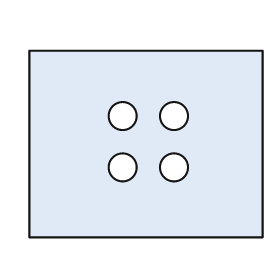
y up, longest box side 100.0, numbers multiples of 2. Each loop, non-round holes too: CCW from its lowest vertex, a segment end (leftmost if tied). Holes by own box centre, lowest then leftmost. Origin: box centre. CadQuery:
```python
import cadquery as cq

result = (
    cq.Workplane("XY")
    .moveTo(-50.0, -40.0)
    .lineTo(50.0, -40.0)
    .lineTo(50.0, 40.0)
    .lineTo(-50.0, 40.0)
    .close()
    .moveTo(-10.0, -10.0)
    .circle(6.0)
    .moveTo(12.0, -10.0)
    .circle(6.0)
    .moveTo(-10.0, 12.0)
    .circle(6.0)
    .moveTo(12.0, 12.0)
    .circle(6.0)
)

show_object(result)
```